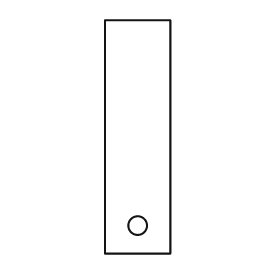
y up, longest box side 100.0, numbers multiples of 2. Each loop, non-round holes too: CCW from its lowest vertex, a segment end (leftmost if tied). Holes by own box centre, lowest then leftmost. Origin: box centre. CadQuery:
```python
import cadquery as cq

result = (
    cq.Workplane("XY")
    .moveTo(-14.0, -50.0)
    .lineTo(14.0, -50.0)
    .lineTo(14.0, 50.0)
    .lineTo(-14.0, 50.0)
    .close()
    .moveTo(0.0, -38.0)
    .circle(4.0)
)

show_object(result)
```